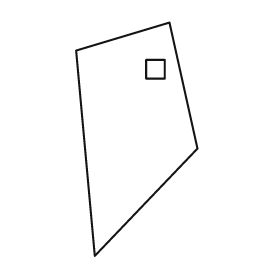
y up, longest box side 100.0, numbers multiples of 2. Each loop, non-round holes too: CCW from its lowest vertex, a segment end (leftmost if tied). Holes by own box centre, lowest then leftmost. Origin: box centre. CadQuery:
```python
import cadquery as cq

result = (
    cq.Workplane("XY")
    .moveTo(-18.0, -50.0)
    .lineTo(26.0, -4.0)
    .lineTo(14.0, 50.0)
    .lineTo(-26.0, 38.0)
    .close()
    .moveTo(4.0, 26.0)
    .lineTo(12.0, 26.0)
    .lineTo(12.0, 34.0)
    .lineTo(4.0, 34.0)
    .close()
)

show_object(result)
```